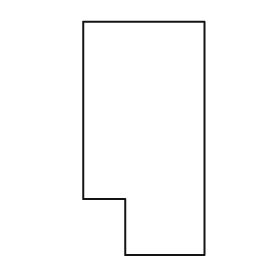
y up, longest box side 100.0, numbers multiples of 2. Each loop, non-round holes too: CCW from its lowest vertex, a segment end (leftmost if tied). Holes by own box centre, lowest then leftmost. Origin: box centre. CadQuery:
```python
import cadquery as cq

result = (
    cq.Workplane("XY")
    .moveTo(-8.0, -50.0)
    .lineTo(26.0, -50.0)
    .lineTo(26.0, 50.0)
    .lineTo(-26.0, 50.0)
    .lineTo(-26.0, -26.0)
    .lineTo(-8.0, -26.0)
    .close()
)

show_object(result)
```